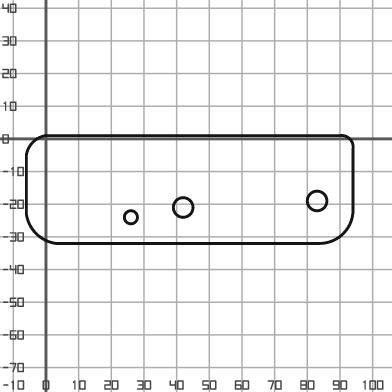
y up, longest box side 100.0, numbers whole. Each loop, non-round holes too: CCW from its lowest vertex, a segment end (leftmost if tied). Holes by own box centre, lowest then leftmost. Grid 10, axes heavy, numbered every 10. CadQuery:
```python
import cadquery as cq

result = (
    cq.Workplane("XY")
    .moveTo(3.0, -32.0)
    .lineTo(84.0, -32.0)
    .threePointArc((91.0, -29.0), (94.0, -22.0))
    .lineTo(94.0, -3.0)
    .threePointArc((93.0, 0.0), (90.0, 1.0))
    .lineTo(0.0, 1.0)
    .threePointArc((-4.0, -1.0), (-6.0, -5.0))
    .lineTo(-6.0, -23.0)
    .threePointArc((-3.0, -29.0), (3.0, -32.0))
    .close()
    .moveTo(26.0, -24.0)
    .circle(2.0)
    .moveTo(42.0, -21.0)
    .circle(3.0)
    .moveTo(83.0, -19.0)
    .circle(3.0)
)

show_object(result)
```